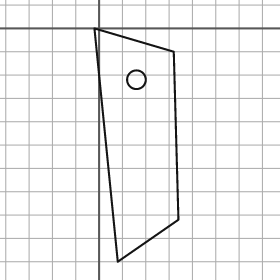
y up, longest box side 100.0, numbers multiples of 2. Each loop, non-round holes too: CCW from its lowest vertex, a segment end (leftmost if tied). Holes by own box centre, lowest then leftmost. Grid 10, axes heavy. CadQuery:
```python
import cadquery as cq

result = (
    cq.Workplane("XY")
    .moveTo(8.0, -100.0)
    .lineTo(34.0, -82.0)
    .lineTo(32.0, -10.0)
    .lineTo(-2.0, 0.0)
    .close()
    .moveTo(16.0, -22.0)
    .circle(4.0)
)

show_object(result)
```